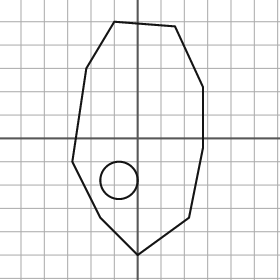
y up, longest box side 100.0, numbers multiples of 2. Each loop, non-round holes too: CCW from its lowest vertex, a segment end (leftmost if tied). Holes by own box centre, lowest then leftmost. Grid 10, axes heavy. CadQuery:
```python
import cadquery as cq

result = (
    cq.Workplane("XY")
    .moveTo(0.0, -50.0)
    .lineTo(22.0, -34.0)
    .lineTo(28.0, -4.0)
    .lineTo(28.0, 22.0)
    .lineTo(16.0, 48.0)
    .lineTo(-10.0, 50.0)
    .lineTo(-22.0, 30.0)
    .lineTo(-28.0, -10.0)
    .lineTo(-16.0, -34.0)
    .close()
    .moveTo(-8.0, -18.0)
    .circle(8.0)
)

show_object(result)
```